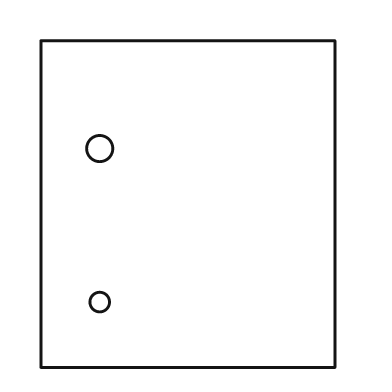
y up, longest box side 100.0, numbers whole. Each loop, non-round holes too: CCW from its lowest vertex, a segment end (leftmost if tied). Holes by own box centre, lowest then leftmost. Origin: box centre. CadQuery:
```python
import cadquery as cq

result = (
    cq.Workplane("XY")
    .moveTo(-45.0, -50.0)
    .lineTo(45.0, -50.0)
    .lineTo(45.0, 50.0)
    .lineTo(-45.0, 50.0)
    .close()
    .moveTo(-27.0, -30.0)
    .circle(3.0)
    .moveTo(-27.0, 17.0)
    .circle(4.0)
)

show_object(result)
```